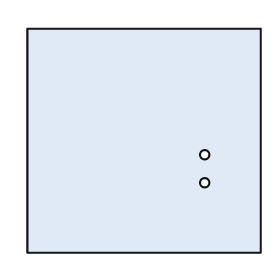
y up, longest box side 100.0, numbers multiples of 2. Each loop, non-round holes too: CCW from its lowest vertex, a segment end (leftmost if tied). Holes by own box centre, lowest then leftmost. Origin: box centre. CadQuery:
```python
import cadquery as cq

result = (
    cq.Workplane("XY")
    .moveTo(-50.0, -48.0)
    .lineTo(50.0, -48.0)
    .lineTo(50.0, 48.0)
    .lineTo(-50.0, 48.0)
    .close()
    .moveTo(26.0, -18.0)
    .circle(2.0)
    .moveTo(26.0, -6.0)
    .circle(2.0)
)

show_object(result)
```